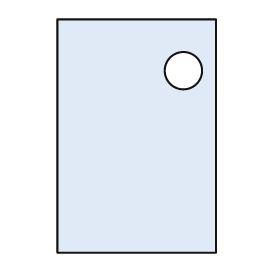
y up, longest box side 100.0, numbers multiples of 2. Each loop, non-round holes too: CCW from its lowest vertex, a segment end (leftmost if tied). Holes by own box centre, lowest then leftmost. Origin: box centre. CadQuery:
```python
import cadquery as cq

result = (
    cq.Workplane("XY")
    .moveTo(-34.0, -50.0)
    .lineTo(34.0, -50.0)
    .lineTo(34.0, 50.0)
    .lineTo(-34.0, 50.0)
    .close()
    .moveTo(20.0, 28.0)
    .circle(8.0)
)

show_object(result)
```